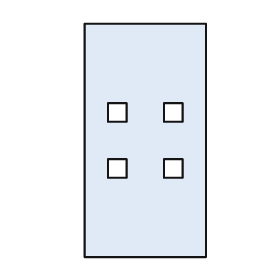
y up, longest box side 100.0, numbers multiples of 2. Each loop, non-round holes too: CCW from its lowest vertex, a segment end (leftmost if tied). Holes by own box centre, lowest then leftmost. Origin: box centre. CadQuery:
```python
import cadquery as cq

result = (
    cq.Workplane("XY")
    .moveTo(-26.0, -50.0)
    .lineTo(26.0, -50.0)
    .lineTo(26.0, 50.0)
    .lineTo(-26.0, 50.0)
    .close()
    .moveTo(-16.0, -16.0)
    .lineTo(-8.0, -16.0)
    .lineTo(-8.0, -8.0)
    .lineTo(-16.0, -8.0)
    .close()
    .moveTo(8.0, -16.0)
    .lineTo(16.0, -16.0)
    .lineTo(16.0, -8.0)
    .lineTo(8.0, -8.0)
    .close()
    .moveTo(-16.0, 8.0)
    .lineTo(-8.0, 8.0)
    .lineTo(-8.0, 16.0)
    .lineTo(-16.0, 16.0)
    .close()
    .moveTo(8.0, 8.0)
    .lineTo(16.0, 8.0)
    .lineTo(16.0, 16.0)
    .lineTo(8.0, 16.0)
    .close()
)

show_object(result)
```